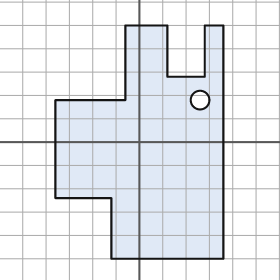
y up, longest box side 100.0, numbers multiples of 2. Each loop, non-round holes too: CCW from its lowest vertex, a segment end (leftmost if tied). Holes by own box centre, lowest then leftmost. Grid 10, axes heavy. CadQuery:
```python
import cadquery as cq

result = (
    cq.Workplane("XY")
    .moveTo(-12.0, -50.0)
    .lineTo(36.0, -50.0)
    .lineTo(36.0, 50.0)
    .lineTo(28.0, 50.0)
    .lineTo(28.0, 28.0)
    .lineTo(12.0, 28.0)
    .lineTo(12.0, 50.0)
    .lineTo(-6.0, 50.0)
    .lineTo(-6.0, 18.0)
    .lineTo(-36.0, 18.0)
    .lineTo(-36.0, -24.0)
    .lineTo(-12.0, -24.0)
    .close()
    .moveTo(26.0, 18.0)
    .circle(4.0)
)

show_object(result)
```